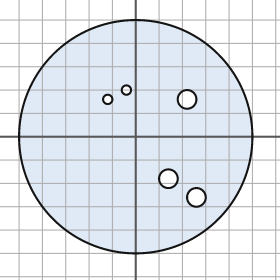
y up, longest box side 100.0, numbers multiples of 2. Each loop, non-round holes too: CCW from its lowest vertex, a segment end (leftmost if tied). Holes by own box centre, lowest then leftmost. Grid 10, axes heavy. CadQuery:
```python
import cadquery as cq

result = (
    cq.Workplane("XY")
    .moveTo(0.0, 0.0)
    .circle(50.0)
    .moveTo(26.0, -26.0)
    .circle(4.0)
    .moveTo(14.0, -18.0)
    .circle(4.0)
    .moveTo(-12.0, 16.0)
    .circle(2.0)
    .moveTo(22.0, 16.0)
    .circle(4.0)
    .moveTo(-4.0, 20.0)
    .circle(2.0)
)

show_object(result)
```